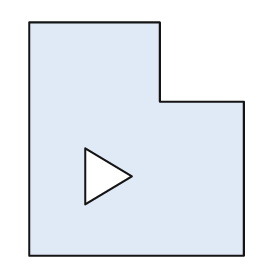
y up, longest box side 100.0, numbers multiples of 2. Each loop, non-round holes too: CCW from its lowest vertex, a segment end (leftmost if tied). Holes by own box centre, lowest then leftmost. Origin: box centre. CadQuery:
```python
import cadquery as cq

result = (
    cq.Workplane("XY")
    .moveTo(-46.0, -50.0)
    .lineTo(46.0, -50.0)
    .lineTo(46.0, 16.0)
    .lineTo(10.0, 16.0)
    .lineTo(10.0, 50.0)
    .lineTo(-46.0, 50.0)
    .close()
    .moveTo(-22.0, -28.0)
    .lineTo(-2.0, -16.0)
    .lineTo(-22.0, -4.0)
    .close()
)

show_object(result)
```